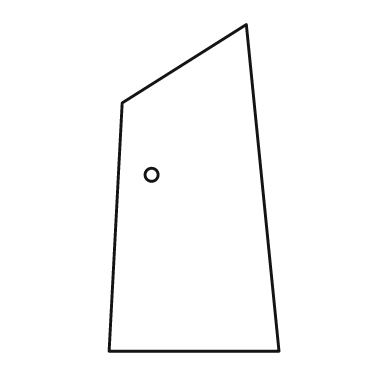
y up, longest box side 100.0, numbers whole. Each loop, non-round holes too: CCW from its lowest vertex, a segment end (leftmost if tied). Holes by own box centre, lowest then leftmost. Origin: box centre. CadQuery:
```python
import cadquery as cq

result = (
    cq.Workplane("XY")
    .moveTo(-26.0, -50.0)
    .lineTo(26.0, -50.0)
    .lineTo(16.0, 50.0)
    .lineTo(-22.0, 26.0)
    .close()
    .moveTo(-13.0, 4.0)
    .circle(2.0)
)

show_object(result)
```